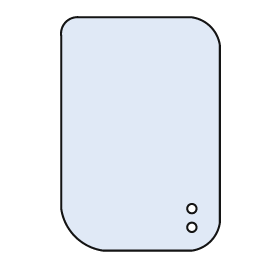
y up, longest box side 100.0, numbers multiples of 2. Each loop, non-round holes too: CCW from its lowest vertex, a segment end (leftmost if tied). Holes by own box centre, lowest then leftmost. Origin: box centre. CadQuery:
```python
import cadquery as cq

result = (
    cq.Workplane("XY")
    .moveTo(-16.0, -50.0)
    .lineTo(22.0, -50.0)
    .threePointArc((30.0, -46.0), (34.0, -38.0))
    .lineTo(34.0, 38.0)
    .threePointArc((30.0, 46.0), (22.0, 50.0))
    .lineTo(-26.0, 50.0)
    .threePointArc((-32.0, 48.0), (-34.0, 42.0))
    .lineTo(-34.0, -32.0)
    .threePointArc((-28.0, -44.0), (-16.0, -50.0))
    .close()
    .moveTo(22.0, -40.0)
    .circle(2.0)
    .moveTo(22.0, -32.0)
    .circle(2.0)
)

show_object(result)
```